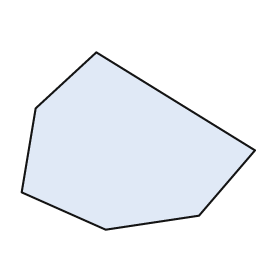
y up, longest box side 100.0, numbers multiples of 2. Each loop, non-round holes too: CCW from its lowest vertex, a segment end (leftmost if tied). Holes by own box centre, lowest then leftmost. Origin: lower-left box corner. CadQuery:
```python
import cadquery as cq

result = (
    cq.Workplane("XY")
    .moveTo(36.0, 0.0)
    .lineTo(76.0, 6.0)
    .lineTo(100.0, 34.0)
    .lineTo(32.0, 76.0)
    .lineTo(6.0, 52.0)
    .lineTo(0.0, 16.0)
    .close()
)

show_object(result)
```